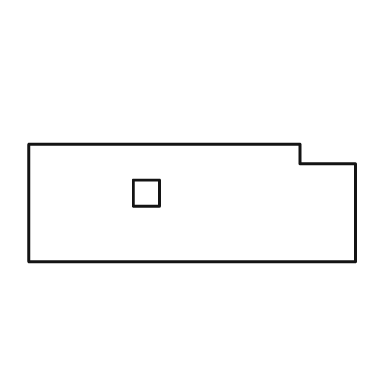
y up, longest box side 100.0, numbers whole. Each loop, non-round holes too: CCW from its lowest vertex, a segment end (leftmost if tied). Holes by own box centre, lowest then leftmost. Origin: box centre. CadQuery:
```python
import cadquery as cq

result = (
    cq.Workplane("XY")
    .moveTo(-50.0, -18.0)
    .lineTo(50.0, -18.0)
    .lineTo(50.0, 12.0)
    .lineTo(33.0, 12.0)
    .lineTo(33.0, 18.0)
    .lineTo(-50.0, 18.0)
    .close()
    .moveTo(-18.0, -1.0)
    .lineTo(-10.0, -1.0)
    .lineTo(-10.0, 7.0)
    .lineTo(-18.0, 7.0)
    .close()
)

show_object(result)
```